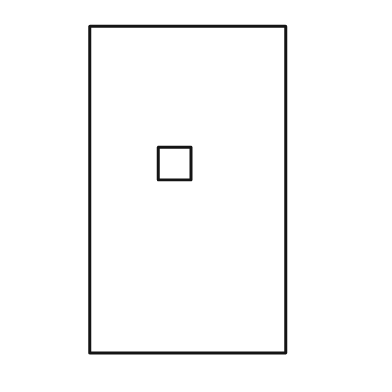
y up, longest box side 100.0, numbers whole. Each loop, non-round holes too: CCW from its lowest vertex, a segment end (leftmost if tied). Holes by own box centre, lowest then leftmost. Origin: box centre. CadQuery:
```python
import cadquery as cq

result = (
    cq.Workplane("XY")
    .moveTo(-30.0, -50.0)
    .lineTo(30.0, -50.0)
    .lineTo(30.0, 50.0)
    .lineTo(-30.0, 50.0)
    .close()
    .moveTo(-9.0, 3.0)
    .lineTo(1.0, 3.0)
    .lineTo(1.0, 13.0)
    .lineTo(-9.0, 13.0)
    .close()
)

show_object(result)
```